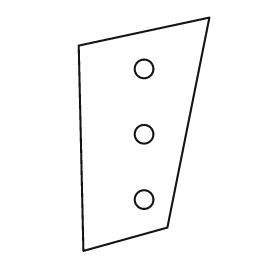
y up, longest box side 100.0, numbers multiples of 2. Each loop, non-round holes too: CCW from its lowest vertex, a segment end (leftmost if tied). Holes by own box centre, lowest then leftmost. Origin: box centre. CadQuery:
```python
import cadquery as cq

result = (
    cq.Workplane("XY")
    .moveTo(-26.0, -50.0)
    .lineTo(10.0, -40.0)
    .lineTo(28.0, 50.0)
    .lineTo(-28.0, 38.0)
    .close()
    .moveTo(0.0, -28.0)
    .circle(4.0)
    .moveTo(0.0, 0.0)
    .circle(4.0)
    .moveTo(0.0, 28.0)
    .circle(4.0)
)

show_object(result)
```